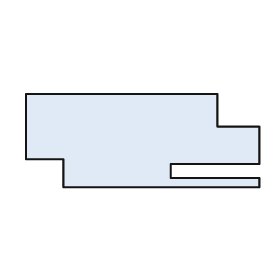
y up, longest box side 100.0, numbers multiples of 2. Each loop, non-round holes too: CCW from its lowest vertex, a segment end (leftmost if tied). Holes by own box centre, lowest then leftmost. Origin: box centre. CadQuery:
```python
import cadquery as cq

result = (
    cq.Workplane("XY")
    .moveTo(-34.0, -20.0)
    .lineTo(50.0, -20.0)
    .lineTo(50.0, -16.0)
    .lineTo(12.0, -16.0)
    .lineTo(12.0, -10.0)
    .lineTo(50.0, -10.0)
    .lineTo(50.0, 6.0)
    .lineTo(32.0, 6.0)
    .lineTo(32.0, 20.0)
    .lineTo(-50.0, 20.0)
    .lineTo(-50.0, -8.0)
    .lineTo(-34.0, -8.0)
    .close()
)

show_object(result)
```